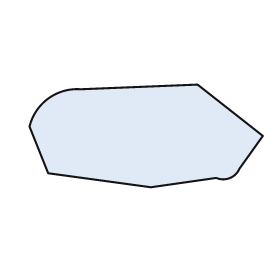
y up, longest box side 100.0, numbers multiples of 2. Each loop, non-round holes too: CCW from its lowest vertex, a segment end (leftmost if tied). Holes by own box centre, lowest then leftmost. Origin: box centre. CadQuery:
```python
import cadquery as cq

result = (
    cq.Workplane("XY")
    .moveTo(2.0, -22.0)
    .lineTo(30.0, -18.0)
    .threePointArc((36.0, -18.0), (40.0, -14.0))
    .lineTo(50.0, 0.0)
    .lineTo(22.0, 22.0)
    .lineTo(-28.0, 20.0)
    .threePointArc((-42.0, 16.0), (-50.0, 4.0))
    .lineTo(-42.0, -16.0)
    .close()
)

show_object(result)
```